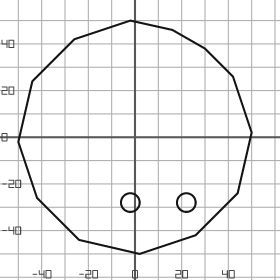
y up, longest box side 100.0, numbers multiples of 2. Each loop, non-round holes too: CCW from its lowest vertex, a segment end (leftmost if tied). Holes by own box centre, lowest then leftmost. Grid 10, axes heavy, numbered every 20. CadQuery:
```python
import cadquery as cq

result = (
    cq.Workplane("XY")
    .moveTo(2.0, -50.0)
    .lineTo(26.0, -42.0)
    .lineTo(44.0, -24.0)
    .lineTo(50.0, 2.0)
    .lineTo(42.0, 26.0)
    .lineTo(30.0, 38.0)
    .lineTo(16.0, 46.0)
    .lineTo(-2.0, 50.0)
    .lineTo(-26.0, 42.0)
    .lineTo(-44.0, 24.0)
    .lineTo(-50.0, -2.0)
    .lineTo(-42.0, -26.0)
    .lineTo(-24.0, -44.0)
    .close()
    .moveTo(-2.0, -28.0)
    .circle(4.0)
    .moveTo(22.0, -28.0)
    .circle(4.0)
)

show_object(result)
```